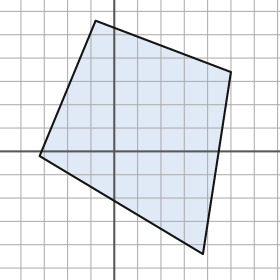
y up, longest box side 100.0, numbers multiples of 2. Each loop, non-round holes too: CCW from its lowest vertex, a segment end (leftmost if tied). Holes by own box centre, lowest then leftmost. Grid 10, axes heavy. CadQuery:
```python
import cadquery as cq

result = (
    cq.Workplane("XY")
    .moveTo(38.0, -44.0)
    .lineTo(50.0, 34.0)
    .lineTo(-8.0, 56.0)
    .lineTo(-32.0, -2.0)
    .close()
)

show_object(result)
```